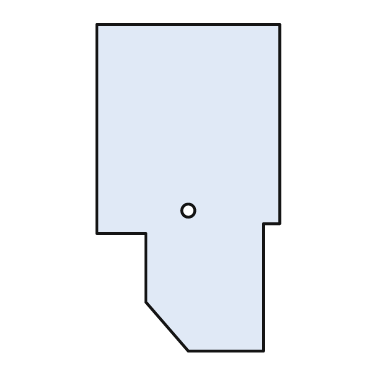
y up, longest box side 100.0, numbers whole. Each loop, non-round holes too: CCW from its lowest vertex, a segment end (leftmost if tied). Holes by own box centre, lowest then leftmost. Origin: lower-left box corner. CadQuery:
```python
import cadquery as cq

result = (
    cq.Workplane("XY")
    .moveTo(28.0, 0.0)
    .lineTo(51.0, 0.0)
    .lineTo(51.0, 39.0)
    .lineTo(56.0, 39.0)
    .lineTo(56.0, 100.0)
    .lineTo(0.0, 100.0)
    .lineTo(0.0, 36.0)
    .lineTo(15.0, 36.0)
    .lineTo(15.0, 15.0)
    .close()
    .moveTo(28.0, 43.0)
    .circle(2.0)
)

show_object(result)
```